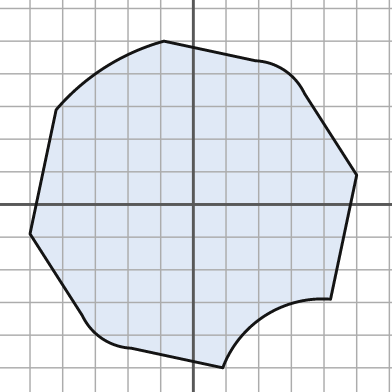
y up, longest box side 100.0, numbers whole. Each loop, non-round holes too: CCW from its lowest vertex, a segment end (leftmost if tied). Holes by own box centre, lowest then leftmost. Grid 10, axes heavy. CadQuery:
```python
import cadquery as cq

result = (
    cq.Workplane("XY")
    .moveTo(9.0, -50.0)
    .threePointArc((22.0, -34.0), (42.0, -29.0))
    .lineTo(50.0, 9.0)
    .lineTo(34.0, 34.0)
    .threePointArc((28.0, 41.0), (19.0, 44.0))
    .lineTo(-9.0, 50.0)
    .threePointArc((-27.0, 42.0), (-42.0, 29.0))
    .lineTo(-50.0, -9.0)
    .lineTo(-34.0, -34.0)
    .threePointArc((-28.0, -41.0), (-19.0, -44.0))
    .close()
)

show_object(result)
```